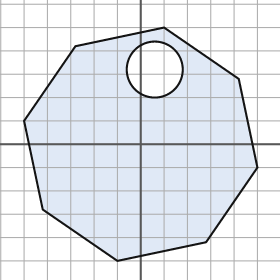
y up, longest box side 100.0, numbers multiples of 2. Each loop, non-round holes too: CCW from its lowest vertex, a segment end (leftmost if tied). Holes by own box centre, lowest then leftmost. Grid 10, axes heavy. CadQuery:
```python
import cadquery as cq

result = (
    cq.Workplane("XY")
    .moveTo(-10.0, -50.0)
    .lineTo(28.0, -42.0)
    .lineTo(50.0, -10.0)
    .lineTo(42.0, 28.0)
    .lineTo(10.0, 50.0)
    .lineTo(-28.0, 42.0)
    .lineTo(-50.0, 10.0)
    .lineTo(-42.0, -28.0)
    .close()
    .moveTo(6.0, 32.0)
    .circle(12.0)
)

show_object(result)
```